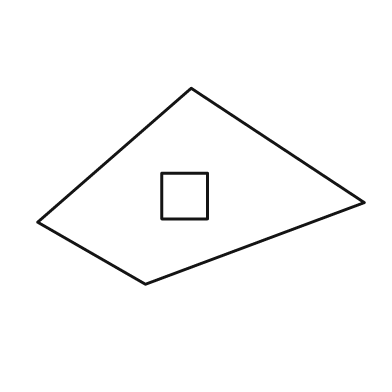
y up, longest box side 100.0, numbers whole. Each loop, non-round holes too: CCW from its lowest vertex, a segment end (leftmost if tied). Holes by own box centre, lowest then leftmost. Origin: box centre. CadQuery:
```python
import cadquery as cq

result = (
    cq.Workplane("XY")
    .moveTo(-17.0, -30.0)
    .lineTo(50.0, -5.0)
    .lineTo(-3.0, 30.0)
    .lineTo(-50.0, -11.0)
    .close()
    .moveTo(-12.0, -10.0)
    .lineTo(2.0, -10.0)
    .lineTo(2.0, 4.0)
    .lineTo(-12.0, 4.0)
    .close()
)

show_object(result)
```